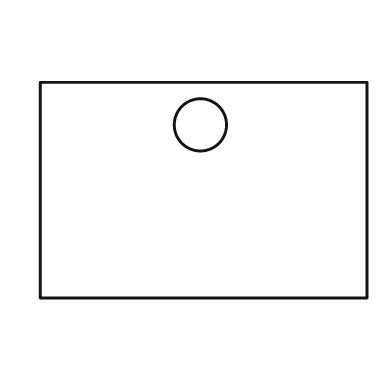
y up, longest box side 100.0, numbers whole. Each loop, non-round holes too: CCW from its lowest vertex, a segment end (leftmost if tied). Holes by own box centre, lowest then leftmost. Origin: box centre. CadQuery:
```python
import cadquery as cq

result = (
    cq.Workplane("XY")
    .moveTo(-50.0, -33.0)
    .lineTo(50.0, -33.0)
    .lineTo(50.0, 33.0)
    .lineTo(-50.0, 33.0)
    .close()
    .moveTo(-1.0, 20.0)
    .circle(8.0)
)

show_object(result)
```